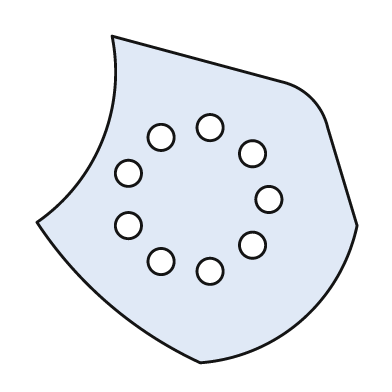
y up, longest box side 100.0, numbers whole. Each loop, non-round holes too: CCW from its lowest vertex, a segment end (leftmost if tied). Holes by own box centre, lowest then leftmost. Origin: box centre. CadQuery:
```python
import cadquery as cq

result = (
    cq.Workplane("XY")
    .moveTo(1.0, -50.0)
    .threePointArc((32.0, -37.0), (49.0, -8.0))
    .lineTo(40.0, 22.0)
    .threePointArc((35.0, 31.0), (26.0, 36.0))
    .lineTo(-26.0, 50.0)
    .threePointArc((-29.0, 18.0), (-49.0, -7.0))
    .threePointArc((-27.0, -32.0), (1.0, -50.0))
    .close()
    .moveTo(4.0, -22.0)
    .circle(4.0)
    .moveTo(-11.0, -19.0)
    .circle(4.0)
    .moveTo(17.0, -14.0)
    .circle(4.0)
    .moveTo(-21.0, -8.0)
    .circle(4.0)
    .moveTo(22.0, 0.0)
    .circle(4.0)
    .moveTo(-21.0, 8.0)
    .circle(4.0)
    .moveTo(17.0, 14.0)
    .circle(4.0)
    .moveTo(-11.0, 19.0)
    .circle(4.0)
    .moveTo(4.0, 22.0)
    .circle(4.0)
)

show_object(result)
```